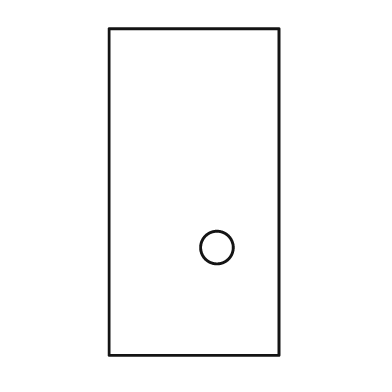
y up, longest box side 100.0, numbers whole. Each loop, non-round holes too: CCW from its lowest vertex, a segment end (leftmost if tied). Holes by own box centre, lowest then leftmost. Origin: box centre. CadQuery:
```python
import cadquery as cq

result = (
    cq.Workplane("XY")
    .moveTo(-26.0, -50.0)
    .lineTo(26.0, -50.0)
    .lineTo(26.0, 50.0)
    .lineTo(-26.0, 50.0)
    .close()
    .moveTo(7.0, -17.0)
    .circle(5.0)
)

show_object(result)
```